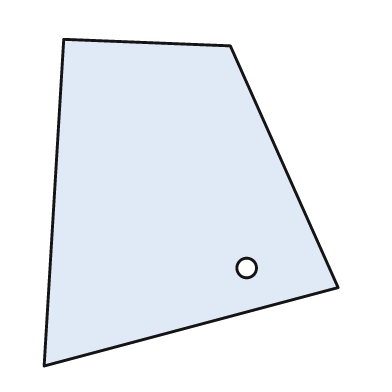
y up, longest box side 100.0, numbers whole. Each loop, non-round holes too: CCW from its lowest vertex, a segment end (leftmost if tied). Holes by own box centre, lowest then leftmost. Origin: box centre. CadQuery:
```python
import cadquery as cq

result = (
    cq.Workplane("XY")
    .moveTo(-45.0, -50.0)
    .lineTo(45.0, -26.0)
    .lineTo(12.0, 48.0)
    .lineTo(-39.0, 50.0)
    .close()
    .moveTo(17.0, -20.0)
    .circle(3.0)
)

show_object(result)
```